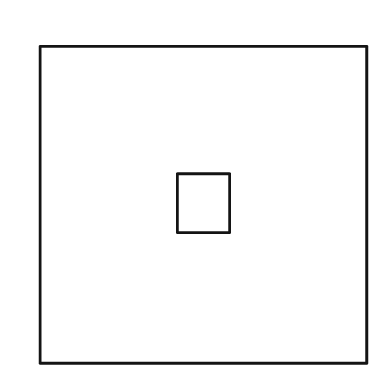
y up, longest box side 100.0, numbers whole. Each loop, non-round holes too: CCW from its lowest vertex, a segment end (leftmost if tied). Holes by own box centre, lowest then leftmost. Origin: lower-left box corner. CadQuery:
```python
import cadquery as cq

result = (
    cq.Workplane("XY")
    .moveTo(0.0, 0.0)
    .lineTo(100.0, 0.0)
    .lineTo(100.0, 97.0)
    .lineTo(0.0, 97.0)
    .close()
    .moveTo(42.0, 40.0)
    .lineTo(58.0, 40.0)
    .lineTo(58.0, 58.0)
    .lineTo(42.0, 58.0)
    .close()
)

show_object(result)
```